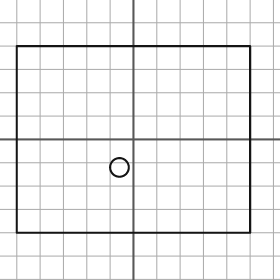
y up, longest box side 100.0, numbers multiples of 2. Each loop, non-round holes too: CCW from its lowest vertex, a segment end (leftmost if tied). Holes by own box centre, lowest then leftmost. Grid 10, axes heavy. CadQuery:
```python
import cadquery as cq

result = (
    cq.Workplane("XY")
    .moveTo(-50.0, -40.0)
    .lineTo(50.0, -40.0)
    .lineTo(50.0, 40.0)
    .lineTo(-50.0, 40.0)
    .close()
    .moveTo(-6.0, -12.0)
    .circle(4.0)
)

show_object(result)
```